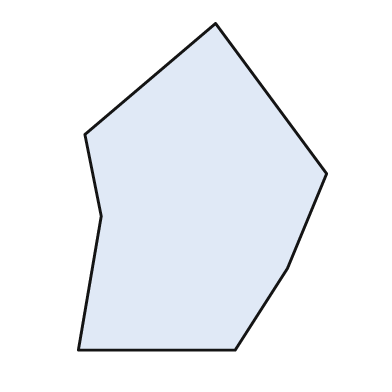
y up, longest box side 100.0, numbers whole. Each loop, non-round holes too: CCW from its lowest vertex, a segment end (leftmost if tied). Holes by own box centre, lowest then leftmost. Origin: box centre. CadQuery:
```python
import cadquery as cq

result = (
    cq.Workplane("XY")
    .moveTo(-38.0, -50.0)
    .lineTo(10.0, -50.0)
    .lineTo(26.0, -25.0)
    .lineTo(38.0, 4.0)
    .lineTo(4.0, 50.0)
    .lineTo(-36.0, 16.0)
    .lineTo(-31.0, -9.0)
    .close()
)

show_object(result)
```